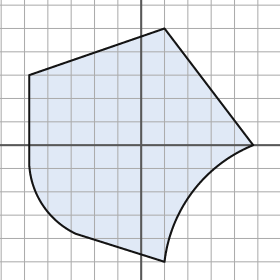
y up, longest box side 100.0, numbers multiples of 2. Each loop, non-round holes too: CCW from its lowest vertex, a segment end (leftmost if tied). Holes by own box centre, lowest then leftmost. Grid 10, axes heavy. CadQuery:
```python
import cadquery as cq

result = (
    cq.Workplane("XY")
    .moveTo(10.0, -50.0)
    .threePointArc((22.0, -20.0), (48.0, 0.0))
    .lineTo(10.0, 50.0)
    .lineTo(-48.0, 30.0)
    .lineTo(-48.0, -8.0)
    .threePointArc((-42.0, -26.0), (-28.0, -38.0))
    .close()
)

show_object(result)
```